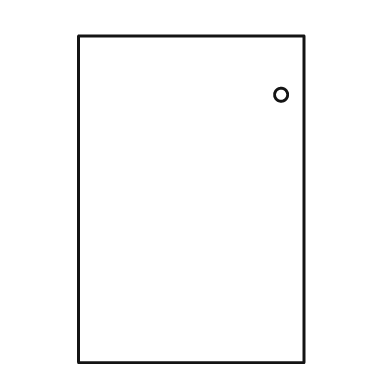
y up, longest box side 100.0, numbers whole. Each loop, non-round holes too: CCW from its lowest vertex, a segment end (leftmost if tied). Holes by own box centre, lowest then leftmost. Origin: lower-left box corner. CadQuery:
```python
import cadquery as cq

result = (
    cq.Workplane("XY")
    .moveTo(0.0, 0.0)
    .lineTo(69.0, 0.0)
    .lineTo(69.0, 100.0)
    .lineTo(0.0, 100.0)
    .close()
    .moveTo(62.0, 82.0)
    .circle(2.0)
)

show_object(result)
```